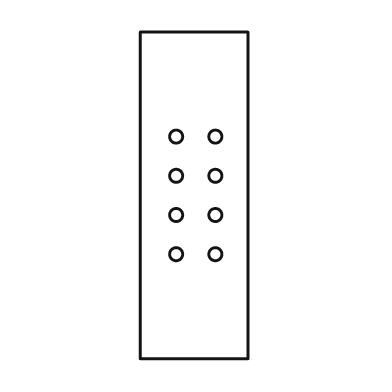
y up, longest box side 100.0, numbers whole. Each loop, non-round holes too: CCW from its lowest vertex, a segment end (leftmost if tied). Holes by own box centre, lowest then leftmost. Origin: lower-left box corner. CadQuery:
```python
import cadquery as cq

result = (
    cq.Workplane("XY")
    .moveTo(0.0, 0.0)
    .lineTo(33.0, 0.0)
    .lineTo(33.0, 100.0)
    .lineTo(0.0, 100.0)
    .close()
    .moveTo(11.0, 32.0)
    .circle(2.0)
    .moveTo(23.0, 32.0)
    .circle(2.0)
    .moveTo(11.0, 44.0)
    .circle(2.0)
    .moveTo(23.0, 44.0)
    .circle(2.0)
    .moveTo(11.0, 56.0)
    .circle(2.0)
    .moveTo(23.0, 56.0)
    .circle(2.0)
    .moveTo(11.0, 68.0)
    .circle(2.0)
    .moveTo(23.0, 68.0)
    .circle(2.0)
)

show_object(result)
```